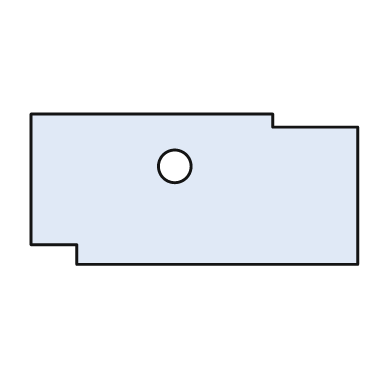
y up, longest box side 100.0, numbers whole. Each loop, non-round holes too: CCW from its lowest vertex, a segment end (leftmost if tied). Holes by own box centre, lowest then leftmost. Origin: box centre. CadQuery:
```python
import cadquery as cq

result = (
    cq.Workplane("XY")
    .moveTo(-36.0, -23.0)
    .lineTo(50.0, -23.0)
    .lineTo(50.0, 19.0)
    .lineTo(24.0, 19.0)
    .lineTo(24.0, 23.0)
    .lineTo(-50.0, 23.0)
    .lineTo(-50.0, -17.0)
    .lineTo(-36.0, -17.0)
    .close()
    .moveTo(-6.0, 7.0)
    .circle(5.0)
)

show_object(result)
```